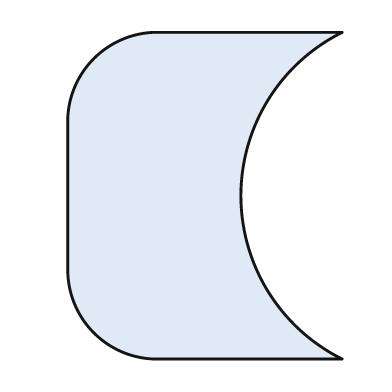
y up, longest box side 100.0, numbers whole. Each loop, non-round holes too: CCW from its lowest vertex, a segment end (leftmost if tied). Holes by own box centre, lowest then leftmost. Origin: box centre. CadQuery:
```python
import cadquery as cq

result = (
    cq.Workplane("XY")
    .moveTo(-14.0, -50.0)
    .lineTo(42.0, -50.0)
    .threePointArc((11.0, 0.0), (42.0, 50.0))
    .lineTo(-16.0, 50.0)
    .threePointArc((-34.0, 42.0), (-42.0, 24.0))
    .lineTo(-42.0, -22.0)
    .threePointArc((-34.0, -42.0), (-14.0, -50.0))
    .close()
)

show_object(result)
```